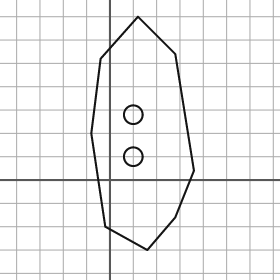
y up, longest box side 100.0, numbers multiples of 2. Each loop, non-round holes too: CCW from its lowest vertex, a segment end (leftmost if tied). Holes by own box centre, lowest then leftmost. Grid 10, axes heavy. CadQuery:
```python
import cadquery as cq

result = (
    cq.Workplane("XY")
    .moveTo(16.0, -30.0)
    .lineTo(28.0, -16.0)
    .lineTo(36.0, 4.0)
    .lineTo(28.0, 54.0)
    .lineTo(12.0, 70.0)
    .lineTo(-4.0, 52.0)
    .lineTo(-8.0, 20.0)
    .lineTo(-2.0, -20.0)
    .close()
    .moveTo(10.0, 10.0)
    .circle(4.0)
    .moveTo(10.0, 28.0)
    .circle(4.0)
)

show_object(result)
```